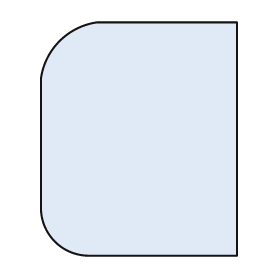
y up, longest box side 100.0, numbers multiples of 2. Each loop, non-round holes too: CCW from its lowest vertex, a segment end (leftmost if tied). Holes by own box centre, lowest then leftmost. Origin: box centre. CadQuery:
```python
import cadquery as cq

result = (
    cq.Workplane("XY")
    .moveTo(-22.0, -50.0)
    .lineTo(42.0, -50.0)
    .lineTo(42.0, 50.0)
    .lineTo(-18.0, 50.0)
    .threePointArc((-34.0, 42.0), (-42.0, 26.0))
    .lineTo(-42.0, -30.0)
    .threePointArc((-36.0, -44.0), (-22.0, -50.0))
    .close()
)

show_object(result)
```